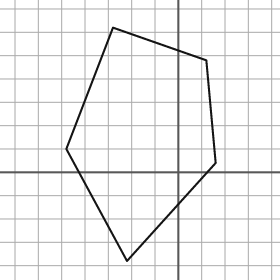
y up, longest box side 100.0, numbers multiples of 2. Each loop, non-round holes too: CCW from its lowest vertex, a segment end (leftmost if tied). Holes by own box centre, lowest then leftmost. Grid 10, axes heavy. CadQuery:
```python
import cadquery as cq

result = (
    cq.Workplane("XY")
    .moveTo(-22.0, -38.0)
    .lineTo(16.0, 4.0)
    .lineTo(12.0, 48.0)
    .lineTo(-28.0, 62.0)
    .lineTo(-48.0, 10.0)
    .close()
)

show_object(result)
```